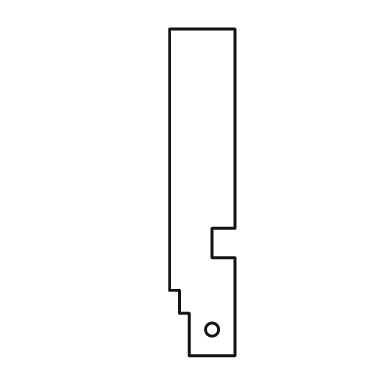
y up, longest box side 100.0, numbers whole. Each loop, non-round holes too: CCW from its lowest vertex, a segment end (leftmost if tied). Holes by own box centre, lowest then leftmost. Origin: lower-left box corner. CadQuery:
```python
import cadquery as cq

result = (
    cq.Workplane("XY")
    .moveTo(6.0, 0.0)
    .lineTo(20.0, 0.0)
    .lineTo(20.0, 30.0)
    .lineTo(13.0, 30.0)
    .lineTo(13.0, 39.0)
    .lineTo(20.0, 39.0)
    .lineTo(20.0, 100.0)
    .lineTo(0.0, 100.0)
    .lineTo(0.0, 20.0)
    .lineTo(3.0, 20.0)
    .lineTo(3.0, 13.0)
    .lineTo(6.0, 13.0)
    .close()
    .moveTo(13.0, 8.0)
    .circle(2.0)
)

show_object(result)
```